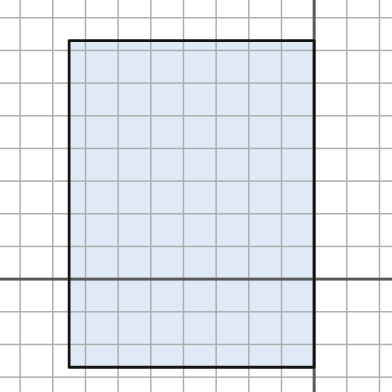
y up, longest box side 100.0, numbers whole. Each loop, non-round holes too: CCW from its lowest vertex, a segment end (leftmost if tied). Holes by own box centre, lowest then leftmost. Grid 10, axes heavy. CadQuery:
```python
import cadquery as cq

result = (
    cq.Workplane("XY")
    .moveTo(-75.0, -27.0)
    .lineTo(0.0, -27.0)
    .lineTo(0.0, 73.0)
    .lineTo(-75.0, 73.0)
    .close()
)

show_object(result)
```